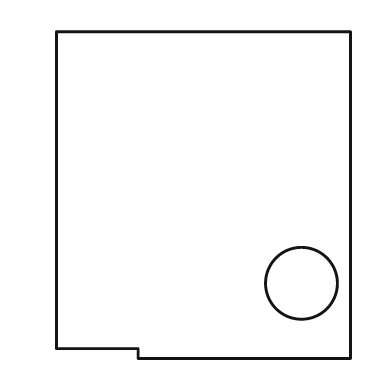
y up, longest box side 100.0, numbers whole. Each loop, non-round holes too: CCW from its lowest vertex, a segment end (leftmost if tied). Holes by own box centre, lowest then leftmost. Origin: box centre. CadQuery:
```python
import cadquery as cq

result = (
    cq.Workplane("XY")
    .moveTo(-20.0, -50.0)
    .lineTo(45.0, -50.0)
    .lineTo(45.0, 50.0)
    .lineTo(-45.0, 50.0)
    .lineTo(-45.0, -47.0)
    .lineTo(-20.0, -47.0)
    .close()
    .moveTo(30.0, -27.0)
    .circle(11.0)
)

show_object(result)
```